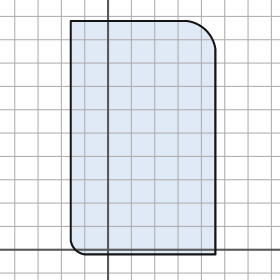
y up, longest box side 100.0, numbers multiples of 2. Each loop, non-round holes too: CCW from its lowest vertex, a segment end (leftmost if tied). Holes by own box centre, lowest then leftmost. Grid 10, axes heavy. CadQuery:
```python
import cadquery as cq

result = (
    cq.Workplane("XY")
    .moveTo(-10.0, -2.0)
    .lineTo(46.0, -2.0)
    .lineTo(46.0, 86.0)
    .threePointArc((42.0, 94.0), (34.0, 98.0))
    .lineTo(-16.0, 98.0)
    .lineTo(-16.0, 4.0)
    .threePointArc((-14.0, 0.0), (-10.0, -2.0))
    .close()
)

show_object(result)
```